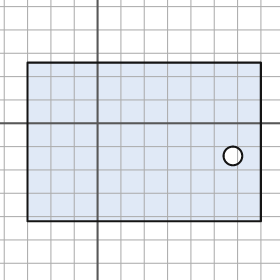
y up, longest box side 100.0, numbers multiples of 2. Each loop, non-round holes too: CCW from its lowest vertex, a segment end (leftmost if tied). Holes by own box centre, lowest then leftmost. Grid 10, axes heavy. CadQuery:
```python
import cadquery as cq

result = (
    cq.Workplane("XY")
    .moveTo(-30.0, -42.0)
    .lineTo(70.0, -42.0)
    .lineTo(70.0, 26.0)
    .lineTo(-30.0, 26.0)
    .close()
    .moveTo(58.0, -14.0)
    .circle(4.0)
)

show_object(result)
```